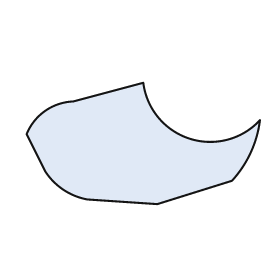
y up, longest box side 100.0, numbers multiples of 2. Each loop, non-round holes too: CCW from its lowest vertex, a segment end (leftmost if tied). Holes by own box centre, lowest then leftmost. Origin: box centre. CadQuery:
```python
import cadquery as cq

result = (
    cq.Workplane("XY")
    .moveTo(6.0, -26.0)
    .lineTo(38.0, -16.0)
    .threePointArc((46.0, -4.0), (50.0, 10.0))
    .threePointArc((20.0, 2.0), (0.0, 26.0))
    .lineTo(-30.0, 18.0)
    .threePointArc((-42.0, 14.0), (-50.0, 4.0))
    .lineTo(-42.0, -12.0)
    .threePointArc((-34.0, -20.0), (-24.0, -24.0))
    .close()
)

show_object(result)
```